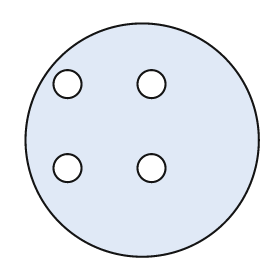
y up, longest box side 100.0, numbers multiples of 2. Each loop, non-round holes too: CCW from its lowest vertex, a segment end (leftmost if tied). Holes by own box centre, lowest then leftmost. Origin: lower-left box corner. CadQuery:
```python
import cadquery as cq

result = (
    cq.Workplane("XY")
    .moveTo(50.0, 50.0)
    .circle(50.0)
    .moveTo(18.0, 38.0)
    .circle(6.0)
    .moveTo(54.0, 38.0)
    .circle(6.0)
    .moveTo(18.0, 74.0)
    .circle(6.0)
    .moveTo(54.0, 74.0)
    .circle(6.0)
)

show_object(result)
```